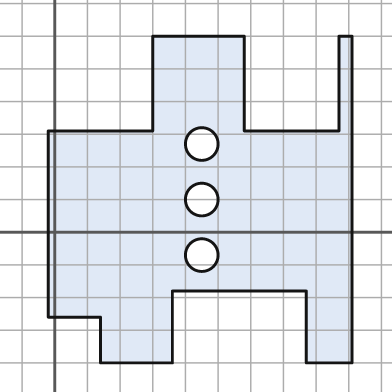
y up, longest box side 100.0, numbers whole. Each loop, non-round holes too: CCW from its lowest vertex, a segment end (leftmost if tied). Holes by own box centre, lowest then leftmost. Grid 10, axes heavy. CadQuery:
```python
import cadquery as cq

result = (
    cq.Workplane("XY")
    .moveTo(14.0, -40.0)
    .lineTo(36.0, -40.0)
    .lineTo(36.0, -18.0)
    .lineTo(77.0, -18.0)
    .lineTo(77.0, -40.0)
    .lineTo(91.0, -40.0)
    .lineTo(91.0, 60.0)
    .lineTo(87.0, 60.0)
    .lineTo(87.0, 31.0)
    .lineTo(58.0, 31.0)
    .lineTo(58.0, 60.0)
    .lineTo(30.0, 60.0)
    .lineTo(30.0, 31.0)
    .lineTo(-2.0, 31.0)
    .lineTo(-2.0, -26.0)
    .lineTo(14.0, -26.0)
    .close()
    .moveTo(45.0, -7.0)
    .circle(5.0)
    .moveTo(45.0, 10.0)
    .circle(5.0)
    .moveTo(45.0, 27.0)
    .circle(5.0)
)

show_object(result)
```